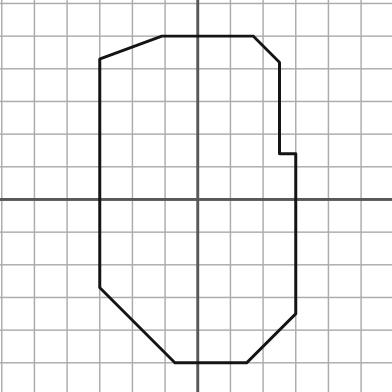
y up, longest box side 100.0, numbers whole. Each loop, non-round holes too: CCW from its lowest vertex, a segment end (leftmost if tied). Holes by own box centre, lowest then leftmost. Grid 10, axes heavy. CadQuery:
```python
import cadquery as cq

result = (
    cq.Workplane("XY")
    .moveTo(-7.0, -50.0)
    .lineTo(15.0, -50.0)
    .lineTo(30.0, -35.0)
    .lineTo(30.0, 14.0)
    .lineTo(25.0, 14.0)
    .lineTo(25.0, 42.0)
    .lineTo(17.0, 50.0)
    .lineTo(-11.0, 50.0)
    .lineTo(-30.0, 43.0)
    .lineTo(-30.0, -27.0)
    .close()
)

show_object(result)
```